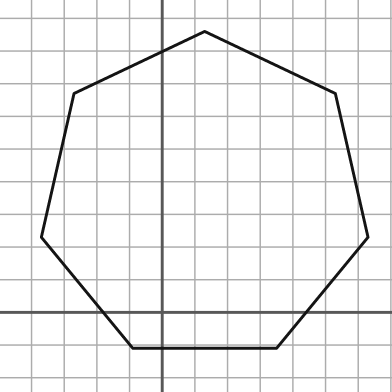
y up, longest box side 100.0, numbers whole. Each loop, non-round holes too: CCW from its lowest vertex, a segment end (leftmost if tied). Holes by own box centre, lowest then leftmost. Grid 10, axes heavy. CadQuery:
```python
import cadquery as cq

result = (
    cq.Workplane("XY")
    .moveTo(-9.0, -11.0)
    .lineTo(35.0, -11.0)
    .lineTo(63.0, 23.0)
    .lineTo(53.0, 67.0)
    .lineTo(13.0, 86.0)
    .lineTo(-27.0, 67.0)
    .lineTo(-37.0, 23.0)
    .close()
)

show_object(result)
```